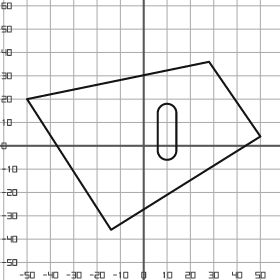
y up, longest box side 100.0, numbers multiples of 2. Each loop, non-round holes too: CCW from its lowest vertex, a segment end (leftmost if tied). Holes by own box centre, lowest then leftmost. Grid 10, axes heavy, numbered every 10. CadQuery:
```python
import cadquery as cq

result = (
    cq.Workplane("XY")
    .moveTo(-14.0, -36.0)
    .lineTo(50.0, 4.0)
    .lineTo(28.0, 36.0)
    .lineTo(-50.0, 20.0)
    .close()
    .moveTo(6.0, -2.0)
    .threePointArc((10.0, -6.0), (14.0, -2.0))
    .lineTo(14.0, 14.0)
    .threePointArc((10.0, 18.0), (6.0, 14.0))
    .close()
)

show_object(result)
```